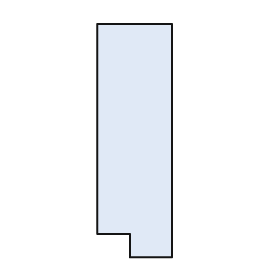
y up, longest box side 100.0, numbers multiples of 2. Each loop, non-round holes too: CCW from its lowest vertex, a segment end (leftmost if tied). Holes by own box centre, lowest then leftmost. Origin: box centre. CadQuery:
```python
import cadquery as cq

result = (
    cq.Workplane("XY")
    .moveTo(-2.0, -50.0)
    .lineTo(16.0, -50.0)
    .lineTo(16.0, 50.0)
    .lineTo(-16.0, 50.0)
    .lineTo(-16.0, -40.0)
    .lineTo(-2.0, -40.0)
    .close()
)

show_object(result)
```